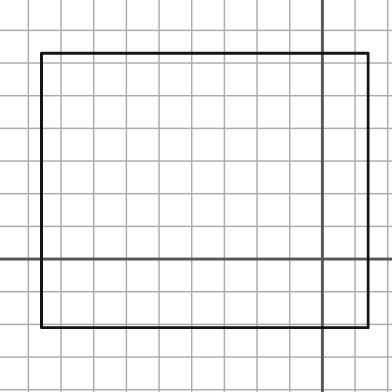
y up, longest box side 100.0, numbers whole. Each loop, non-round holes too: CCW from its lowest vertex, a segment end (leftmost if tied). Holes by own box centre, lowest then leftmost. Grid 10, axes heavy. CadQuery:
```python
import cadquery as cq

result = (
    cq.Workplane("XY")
    .moveTo(-86.0, -21.0)
    .lineTo(14.0, -21.0)
    .lineTo(14.0, 63.0)
    .lineTo(-86.0, 63.0)
    .close()
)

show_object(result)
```